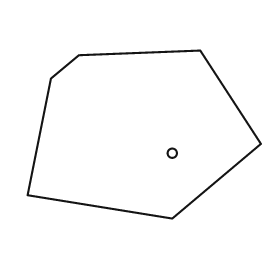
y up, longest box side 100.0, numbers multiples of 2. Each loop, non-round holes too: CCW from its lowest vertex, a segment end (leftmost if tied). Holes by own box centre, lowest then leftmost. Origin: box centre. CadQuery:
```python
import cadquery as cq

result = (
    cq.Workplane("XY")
    .moveTo(12.0, -36.0)
    .lineTo(50.0, -4.0)
    .lineTo(24.0, 36.0)
    .lineTo(-28.0, 34.0)
    .lineTo(-40.0, 24.0)
    .lineTo(-50.0, -26.0)
    .close()
    .moveTo(12.0, -8.0)
    .circle(2.0)
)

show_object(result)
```